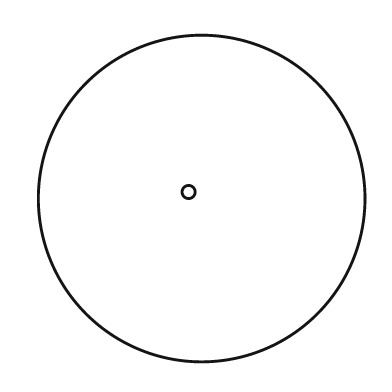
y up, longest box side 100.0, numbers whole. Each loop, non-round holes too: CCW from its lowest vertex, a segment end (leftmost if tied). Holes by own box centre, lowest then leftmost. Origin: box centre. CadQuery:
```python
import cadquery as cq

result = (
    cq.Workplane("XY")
    .moveTo(0.0, 0.0)
    .circle(50.0)
    .moveTo(-4.0, 2.0)
    .circle(2.0)
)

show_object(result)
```